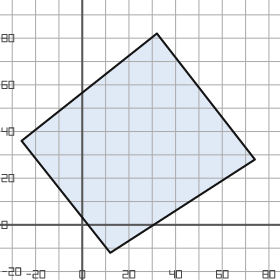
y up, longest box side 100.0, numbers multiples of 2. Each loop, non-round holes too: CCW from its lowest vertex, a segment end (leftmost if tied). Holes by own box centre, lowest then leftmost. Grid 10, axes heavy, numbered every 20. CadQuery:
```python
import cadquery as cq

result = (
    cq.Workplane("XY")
    .moveTo(12.0, -12.0)
    .lineTo(74.0, 28.0)
    .lineTo(32.0, 82.0)
    .lineTo(-26.0, 36.0)
    .close()
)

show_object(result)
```